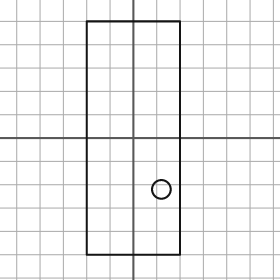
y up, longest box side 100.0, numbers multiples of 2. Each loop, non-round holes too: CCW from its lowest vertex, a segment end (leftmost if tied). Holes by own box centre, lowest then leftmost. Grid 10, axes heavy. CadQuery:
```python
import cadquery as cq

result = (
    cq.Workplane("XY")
    .moveTo(-20.0, -50.0)
    .lineTo(20.0, -50.0)
    .lineTo(20.0, 50.0)
    .lineTo(-20.0, 50.0)
    .close()
    .moveTo(12.0, -22.0)
    .circle(4.0)
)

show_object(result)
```